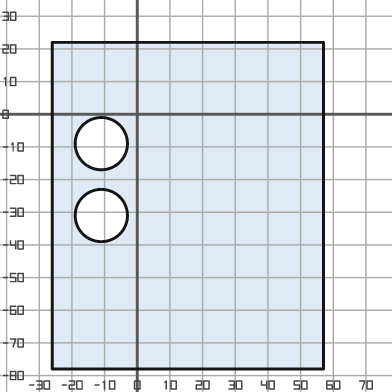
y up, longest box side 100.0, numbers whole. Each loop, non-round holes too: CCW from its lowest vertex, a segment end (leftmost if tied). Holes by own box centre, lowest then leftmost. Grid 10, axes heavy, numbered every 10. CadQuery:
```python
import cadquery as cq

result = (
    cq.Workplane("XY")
    .moveTo(-26.0, -78.0)
    .lineTo(57.0, -78.0)
    .lineTo(57.0, 22.0)
    .lineTo(-26.0, 22.0)
    .close()
    .moveTo(-11.0, -31.0)
    .circle(8.0)
    .moveTo(-11.0, -9.0)
    .circle(8.0)
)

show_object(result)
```